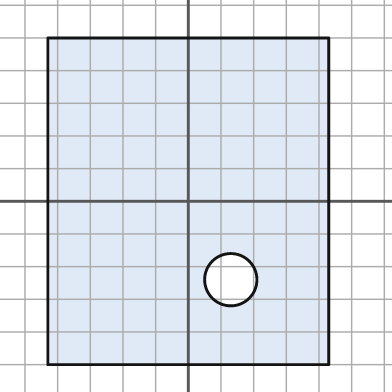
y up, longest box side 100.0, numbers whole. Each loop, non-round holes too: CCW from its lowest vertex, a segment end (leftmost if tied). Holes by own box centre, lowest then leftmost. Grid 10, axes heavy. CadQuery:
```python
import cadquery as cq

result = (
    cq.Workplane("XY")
    .moveTo(-43.0, -50.0)
    .lineTo(43.0, -50.0)
    .lineTo(43.0, 50.0)
    .lineTo(-43.0, 50.0)
    .close()
    .moveTo(13.0, -24.0)
    .circle(8.0)
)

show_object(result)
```